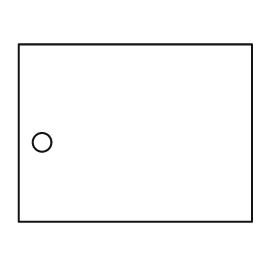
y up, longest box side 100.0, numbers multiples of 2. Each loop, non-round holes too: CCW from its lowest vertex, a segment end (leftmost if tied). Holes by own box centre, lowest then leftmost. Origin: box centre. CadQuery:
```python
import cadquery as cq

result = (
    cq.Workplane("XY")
    .moveTo(-50.0, -38.0)
    .lineTo(50.0, -38.0)
    .lineTo(50.0, 38.0)
    .lineTo(-50.0, 38.0)
    .close()
    .moveTo(-40.0, -4.0)
    .circle(4.0)
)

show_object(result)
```